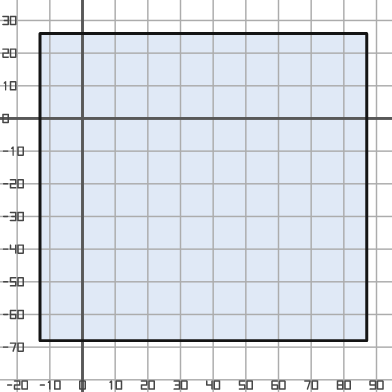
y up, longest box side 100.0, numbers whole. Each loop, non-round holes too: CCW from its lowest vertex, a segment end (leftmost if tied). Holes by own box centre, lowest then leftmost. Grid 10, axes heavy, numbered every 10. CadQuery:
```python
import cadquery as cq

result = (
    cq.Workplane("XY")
    .moveTo(-13.0, -68.0)
    .lineTo(87.0, -68.0)
    .lineTo(87.0, 26.0)
    .lineTo(-13.0, 26.0)
    .close()
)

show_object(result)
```